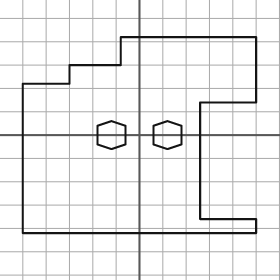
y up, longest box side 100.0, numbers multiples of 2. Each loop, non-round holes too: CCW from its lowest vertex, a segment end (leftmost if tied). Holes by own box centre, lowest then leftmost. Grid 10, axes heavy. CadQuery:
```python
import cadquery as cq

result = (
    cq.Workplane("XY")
    .moveTo(-50.0, -42.0)
    .lineTo(50.0, -42.0)
    .lineTo(50.0, -36.0)
    .lineTo(26.0, -36.0)
    .lineTo(26.0, 14.0)
    .lineTo(50.0, 14.0)
    .lineTo(50.0, 42.0)
    .lineTo(-8.0, 42.0)
    .lineTo(-8.0, 30.0)
    .lineTo(-30.0, 30.0)
    .lineTo(-30.0, 22.0)
    .lineTo(-50.0, 22.0)
    .close()
    .moveTo(-12.0, -6.0)
    .lineTo(-6.0, -4.0)
    .lineTo(-6.0, 4.0)
    .lineTo(-12.0, 6.0)
    .lineTo(-18.0, 4.0)
    .lineTo(-18.0, -4.0)
    .close()
    .moveTo(12.0, -6.0)
    .lineTo(18.0, -4.0)
    .lineTo(18.0, 4.0)
    .lineTo(12.0, 6.0)
    .lineTo(6.0, 4.0)
    .lineTo(6.0, -4.0)
    .close()
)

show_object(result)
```